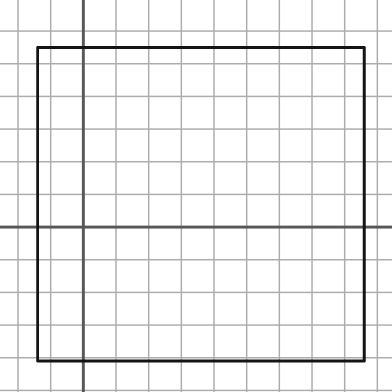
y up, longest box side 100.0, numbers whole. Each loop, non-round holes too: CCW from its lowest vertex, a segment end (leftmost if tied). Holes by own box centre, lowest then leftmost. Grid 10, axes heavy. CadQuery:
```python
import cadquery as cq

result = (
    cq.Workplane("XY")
    .moveTo(-14.0, -41.0)
    .lineTo(86.0, -41.0)
    .lineTo(86.0, 55.0)
    .lineTo(-14.0, 55.0)
    .close()
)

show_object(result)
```